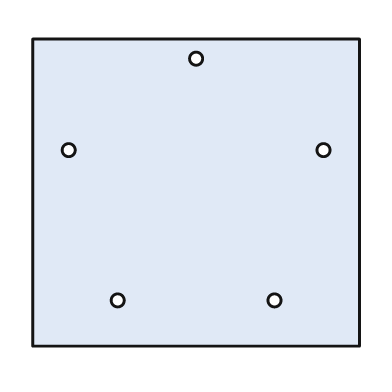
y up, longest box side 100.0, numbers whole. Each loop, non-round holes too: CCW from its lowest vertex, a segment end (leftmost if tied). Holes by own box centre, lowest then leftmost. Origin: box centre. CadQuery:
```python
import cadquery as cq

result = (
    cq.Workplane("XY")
    .moveTo(-50.0, -47.0)
    .lineTo(50.0, -47.0)
    .lineTo(50.0, 47.0)
    .lineTo(-50.0, 47.0)
    .close()
    .moveTo(-24.0, -33.0)
    .circle(2.0)
    .moveTo(24.0, -33.0)
    .circle(2.0)
    .moveTo(-39.0, 13.0)
    .circle(2.0)
    .moveTo(39.0, 13.0)
    .circle(2.0)
    .moveTo(0.0, 41.0)
    .circle(2.0)
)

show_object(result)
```